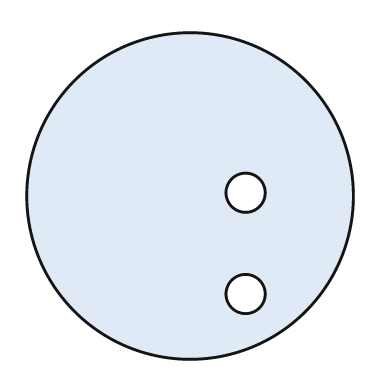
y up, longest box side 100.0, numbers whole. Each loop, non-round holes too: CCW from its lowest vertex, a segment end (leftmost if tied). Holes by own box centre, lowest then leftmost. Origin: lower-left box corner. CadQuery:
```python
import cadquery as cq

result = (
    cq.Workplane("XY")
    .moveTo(50.0, 50.0)
    .circle(50.0)
    .moveTo(67.0, 20.0)
    .circle(6.0)
    .moveTo(67.0, 51.0)
    .circle(6.0)
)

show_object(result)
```